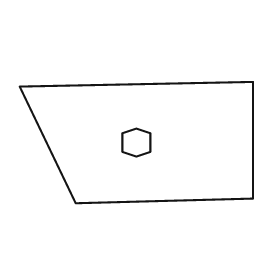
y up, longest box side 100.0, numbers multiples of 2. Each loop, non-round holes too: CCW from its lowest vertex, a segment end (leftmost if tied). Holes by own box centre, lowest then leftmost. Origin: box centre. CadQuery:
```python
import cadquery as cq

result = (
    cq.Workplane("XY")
    .moveTo(-26.0, -26.0)
    .lineTo(50.0, -24.0)
    .lineTo(50.0, 26.0)
    .lineTo(-50.0, 24.0)
    .close()
    .moveTo(0.0, -6.0)
    .lineTo(6.0, -4.0)
    .lineTo(6.0, 4.0)
    .lineTo(0.0, 6.0)
    .lineTo(-6.0, 4.0)
    .lineTo(-6.0, -4.0)
    .close()
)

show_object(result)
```